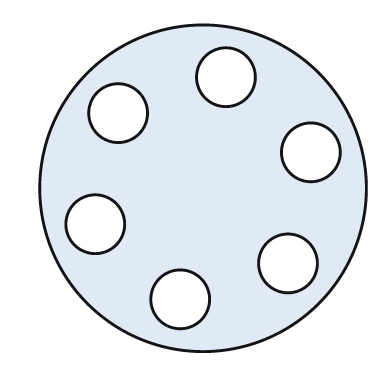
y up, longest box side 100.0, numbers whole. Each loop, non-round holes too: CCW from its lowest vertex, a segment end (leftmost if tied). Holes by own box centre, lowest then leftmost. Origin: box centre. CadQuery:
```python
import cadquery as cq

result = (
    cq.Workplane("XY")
    .moveTo(0.0, 0.0)
    .circle(50.0)
    .moveTo(-7.0, -34.0)
    .circle(9.0)
    .moveTo(26.0, -23.0)
    .circle(9.0)
    .moveTo(-33.0, -11.0)
    .circle(9.0)
    .moveTo(33.0, 11.0)
    .circle(9.0)
    .moveTo(-26.0, 23.0)
    .circle(9.0)
    .moveTo(7.0, 34.0)
    .circle(9.0)
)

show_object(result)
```